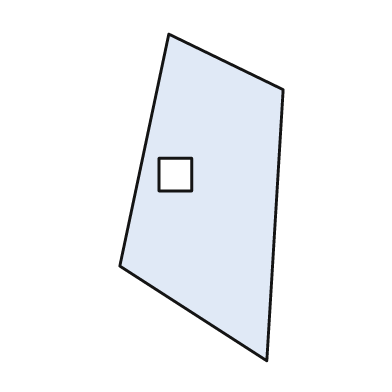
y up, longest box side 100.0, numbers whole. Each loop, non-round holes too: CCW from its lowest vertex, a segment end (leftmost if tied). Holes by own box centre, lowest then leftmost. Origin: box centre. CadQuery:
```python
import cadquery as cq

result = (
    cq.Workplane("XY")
    .moveTo(20.0, -50.0)
    .lineTo(25.0, 33.0)
    .lineTo(-10.0, 50.0)
    .lineTo(-25.0, -21.0)
    .close()
    .moveTo(-13.0, 2.0)
    .lineTo(-3.0, 2.0)
    .lineTo(-3.0, 12.0)
    .lineTo(-13.0, 12.0)
    .close()
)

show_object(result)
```